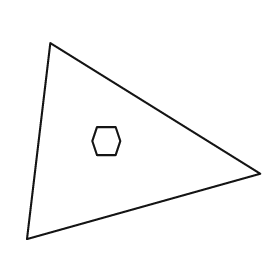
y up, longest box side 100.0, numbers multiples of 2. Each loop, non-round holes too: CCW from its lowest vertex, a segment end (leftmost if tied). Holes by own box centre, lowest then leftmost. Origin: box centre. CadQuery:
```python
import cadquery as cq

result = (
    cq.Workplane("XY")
    .moveTo(-50.0, -42.0)
    .lineTo(50.0, -14.0)
    .lineTo(-40.0, 42.0)
    .close()
    .moveTo(-20.0, -6.0)
    .lineTo(-12.0, -6.0)
    .lineTo(-10.0, 0.0)
    .lineTo(-12.0, 6.0)
    .lineTo(-20.0, 6.0)
    .lineTo(-22.0, 0.0)
    .close()
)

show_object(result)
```